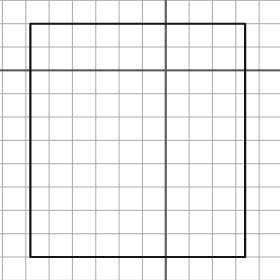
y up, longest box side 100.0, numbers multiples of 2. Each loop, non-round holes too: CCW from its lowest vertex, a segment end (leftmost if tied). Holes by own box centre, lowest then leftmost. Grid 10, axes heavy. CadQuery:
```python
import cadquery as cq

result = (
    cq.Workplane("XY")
    .moveTo(-58.0, -80.0)
    .lineTo(34.0, -80.0)
    .lineTo(34.0, 20.0)
    .lineTo(-58.0, 20.0)
    .close()
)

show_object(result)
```